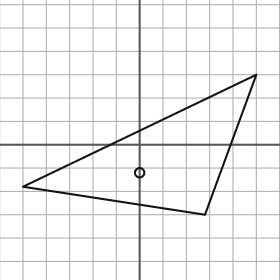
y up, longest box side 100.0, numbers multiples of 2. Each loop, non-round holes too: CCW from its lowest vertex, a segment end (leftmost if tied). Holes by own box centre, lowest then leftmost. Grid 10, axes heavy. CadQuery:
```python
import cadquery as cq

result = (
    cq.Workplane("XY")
    .moveTo(28.0, -30.0)
    .lineTo(50.0, 30.0)
    .lineTo(-50.0, -18.0)
    .close()
    .moveTo(0.0, -12.0)
    .circle(2.0)
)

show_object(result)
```